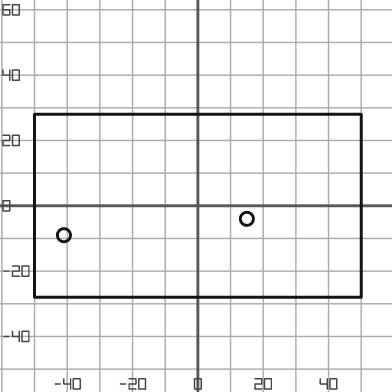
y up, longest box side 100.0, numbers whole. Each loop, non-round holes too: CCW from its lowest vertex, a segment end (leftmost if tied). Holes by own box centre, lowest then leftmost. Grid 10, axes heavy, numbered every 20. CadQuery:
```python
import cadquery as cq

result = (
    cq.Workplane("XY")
    .moveTo(-50.0, -28.0)
    .lineTo(50.0, -28.0)
    .lineTo(50.0, 28.0)
    .lineTo(-50.0, 28.0)
    .close()
    .moveTo(-41.0, -9.0)
    .circle(2.0)
    .moveTo(15.0, -4.0)
    .circle(2.0)
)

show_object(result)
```